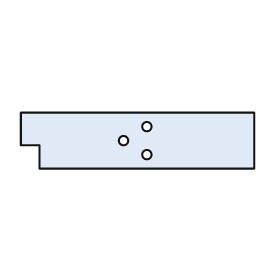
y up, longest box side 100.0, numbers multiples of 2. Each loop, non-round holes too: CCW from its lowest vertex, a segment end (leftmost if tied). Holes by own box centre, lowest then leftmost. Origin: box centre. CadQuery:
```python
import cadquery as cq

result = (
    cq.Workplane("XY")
    .moveTo(-42.0, -12.0)
    .lineTo(50.0, -12.0)
    .lineTo(50.0, 12.0)
    .lineTo(-50.0, 12.0)
    .lineTo(-50.0, -2.0)
    .lineTo(-42.0, -2.0)
    .close()
    .moveTo(4.0, -6.0)
    .circle(2.0)
    .moveTo(-6.0, 0.0)
    .circle(2.0)
    .moveTo(4.0, 6.0)
    .circle(2.0)
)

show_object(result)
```